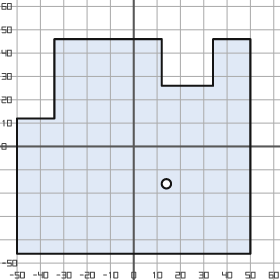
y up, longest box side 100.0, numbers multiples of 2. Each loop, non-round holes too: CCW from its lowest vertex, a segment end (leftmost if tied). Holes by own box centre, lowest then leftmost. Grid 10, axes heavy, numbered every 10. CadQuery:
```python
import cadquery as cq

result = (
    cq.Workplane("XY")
    .moveTo(-50.0, -46.0)
    .lineTo(50.0, -46.0)
    .lineTo(50.0, 46.0)
    .lineTo(34.0, 46.0)
    .lineTo(34.0, 26.0)
    .lineTo(12.0, 26.0)
    .lineTo(12.0, 46.0)
    .lineTo(-34.0, 46.0)
    .lineTo(-34.0, 12.0)
    .lineTo(-50.0, 12.0)
    .close()
    .moveTo(14.0, -16.0)
    .circle(2.0)
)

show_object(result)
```